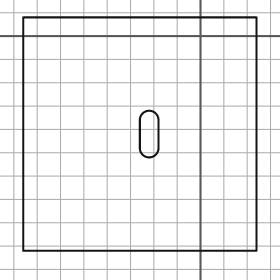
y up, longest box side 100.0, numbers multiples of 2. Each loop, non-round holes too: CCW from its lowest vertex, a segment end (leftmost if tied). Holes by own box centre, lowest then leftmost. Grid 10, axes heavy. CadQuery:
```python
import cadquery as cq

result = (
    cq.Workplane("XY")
    .moveTo(-76.0, -92.0)
    .lineTo(24.0, -92.0)
    .lineTo(24.0, 8.0)
    .lineTo(-76.0, 8.0)
    .close()
    .moveTo(-26.0, -48.0)
    .threePointArc((-22.0, -52.0), (-18.0, -48.0))
    .lineTo(-18.0, -36.0)
    .threePointArc((-22.0, -32.0), (-26.0, -36.0))
    .close()
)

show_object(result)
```